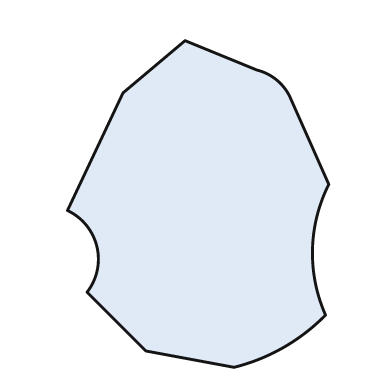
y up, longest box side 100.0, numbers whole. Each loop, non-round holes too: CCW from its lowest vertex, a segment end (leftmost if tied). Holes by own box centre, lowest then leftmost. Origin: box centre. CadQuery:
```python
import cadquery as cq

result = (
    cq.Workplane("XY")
    .moveTo(11.0, -50.0)
    .threePointArc((26.0, -44.0), (39.0, -34.0))
    .threePointArc((35.0, -14.0), (40.0, 6.0))
    .lineTo(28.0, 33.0)
    .threePointArc((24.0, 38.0), (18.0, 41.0))
    .lineTo(-4.0, 50.0)
    .lineTo(-23.0, 34.0)
    .lineTo(-40.0, -2.0)
    .threePointArc((-31.0, -13.0), (-34.0, -27.0))
    .lineTo(-16.0, -45.0)
    .close()
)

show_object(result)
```